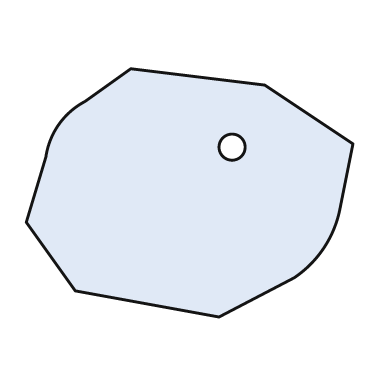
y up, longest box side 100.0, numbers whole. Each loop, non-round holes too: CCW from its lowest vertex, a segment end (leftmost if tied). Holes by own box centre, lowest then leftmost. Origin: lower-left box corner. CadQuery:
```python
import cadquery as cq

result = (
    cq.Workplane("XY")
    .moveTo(59.0, 0.0)
    .lineTo(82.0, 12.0)
    .threePointArc((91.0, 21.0), (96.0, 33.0))
    .lineTo(100.0, 53.0)
    .lineTo(73.0, 71.0)
    .lineTo(32.0, 76.0)
    .lineTo(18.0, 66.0)
    .threePointArc((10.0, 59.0), (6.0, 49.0))
    .lineTo(0.0, 29.0)
    .lineTo(15.0, 8.0)
    .close()
    .moveTo(63.0, 52.0)
    .circle(4.0)
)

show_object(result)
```